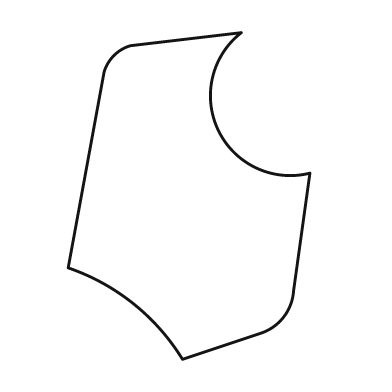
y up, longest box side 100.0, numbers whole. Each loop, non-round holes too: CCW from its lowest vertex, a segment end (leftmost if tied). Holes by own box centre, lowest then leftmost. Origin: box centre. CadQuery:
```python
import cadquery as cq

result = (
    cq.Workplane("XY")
    .moveTo(-2.0, -50.0)
    .lineTo(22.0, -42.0)
    .threePointArc((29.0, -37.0), (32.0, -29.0))
    .lineTo(37.0, 7.0)
    .threePointArc((9.0, 20.0), (16.0, 50.0))
    .lineTo(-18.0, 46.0)
    .threePointArc((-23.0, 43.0), (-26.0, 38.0))
    .lineTo(-37.0, -22.0)
    .threePointArc((-17.0, -33.0), (-2.0, -50.0))
    .close()
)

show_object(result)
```